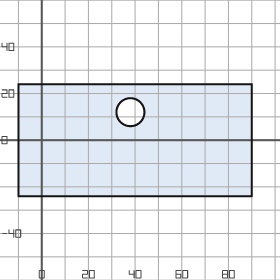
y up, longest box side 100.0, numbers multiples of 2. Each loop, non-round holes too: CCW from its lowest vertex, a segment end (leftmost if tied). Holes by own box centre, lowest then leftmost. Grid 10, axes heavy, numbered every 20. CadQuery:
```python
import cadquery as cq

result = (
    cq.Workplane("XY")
    .moveTo(-10.0, -24.0)
    .lineTo(90.0, -24.0)
    .lineTo(90.0, 24.0)
    .lineTo(-10.0, 24.0)
    .close()
    .moveTo(38.0, 12.0)
    .circle(6.0)
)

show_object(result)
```